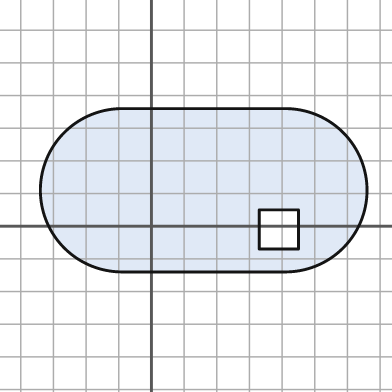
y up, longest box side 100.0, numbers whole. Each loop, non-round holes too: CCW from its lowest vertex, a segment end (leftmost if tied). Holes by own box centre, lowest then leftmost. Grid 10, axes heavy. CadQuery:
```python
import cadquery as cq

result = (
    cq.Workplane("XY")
    .moveTo(-9.0, -14.0)
    .lineTo(41.0, -14.0)
    .threePointArc((66.0, 11.0), (41.0, 36.0))
    .lineTo(-9.0, 36.0)
    .threePointArc((-34.0, 11.0), (-9.0, -14.0))
    .close()
    .moveTo(33.0, -7.0)
    .lineTo(45.0, -7.0)
    .lineTo(45.0, 5.0)
    .lineTo(33.0, 5.0)
    .close()
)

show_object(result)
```